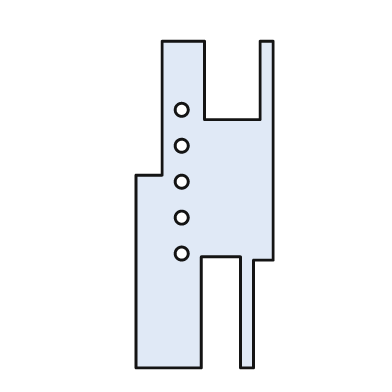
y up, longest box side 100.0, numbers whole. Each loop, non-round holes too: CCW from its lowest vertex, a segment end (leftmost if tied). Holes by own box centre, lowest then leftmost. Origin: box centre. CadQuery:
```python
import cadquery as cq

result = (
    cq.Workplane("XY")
    .moveTo(-21.0, -50.0)
    .lineTo(-1.0, -50.0)
    .lineTo(-1.0, -16.0)
    .lineTo(11.0, -16.0)
    .lineTo(11.0, -50.0)
    .lineTo(15.0, -50.0)
    .lineTo(15.0, -17.0)
    .lineTo(21.0, -17.0)
    .lineTo(21.0, 50.0)
    .lineTo(17.0, 50.0)
    .lineTo(17.0, 26.0)
    .lineTo(0.0, 26.0)
    .lineTo(0.0, 50.0)
    .lineTo(-13.0, 50.0)
    .lineTo(-13.0, 9.0)
    .lineTo(-21.0, 9.0)
    .close()
    .moveTo(-7.0, -15.0)
    .circle(2.0)
    .moveTo(-7.0, -4.0)
    .circle(2.0)
    .moveTo(-7.0, 7.0)
    .circle(2.0)
    .moveTo(-7.0, 18.0)
    .circle(2.0)
    .moveTo(-7.0, 29.0)
    .circle(2.0)
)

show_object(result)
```